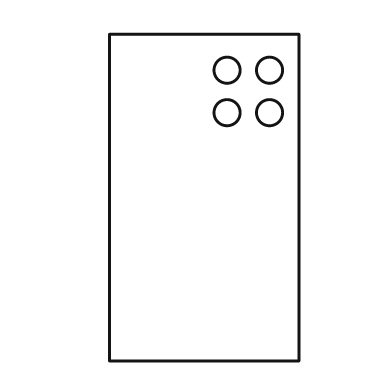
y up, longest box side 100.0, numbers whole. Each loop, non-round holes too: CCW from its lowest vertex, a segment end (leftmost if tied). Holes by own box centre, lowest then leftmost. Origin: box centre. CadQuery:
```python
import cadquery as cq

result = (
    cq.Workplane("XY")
    .moveTo(-29.0, -50.0)
    .lineTo(29.0, -50.0)
    .lineTo(29.0, 50.0)
    .lineTo(-29.0, 50.0)
    .close()
    .moveTo(7.0, 26.0)
    .circle(4.0)
    .moveTo(20.0, 26.0)
    .circle(4.0)
    .moveTo(7.0, 39.0)
    .circle(4.0)
    .moveTo(20.0, 39.0)
    .circle(4.0)
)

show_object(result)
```